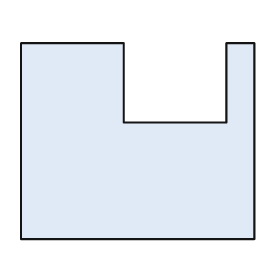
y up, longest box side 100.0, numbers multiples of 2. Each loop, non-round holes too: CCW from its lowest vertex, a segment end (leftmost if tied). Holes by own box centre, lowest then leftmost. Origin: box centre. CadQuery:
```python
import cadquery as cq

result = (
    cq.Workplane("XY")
    .moveTo(-50.0, -42.0)
    .lineTo(50.0, -42.0)
    .lineTo(50.0, 42.0)
    .lineTo(38.0, 42.0)
    .lineTo(38.0, 8.0)
    .lineTo(-6.0, 8.0)
    .lineTo(-6.0, 42.0)
    .lineTo(-50.0, 42.0)
    .close()
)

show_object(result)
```